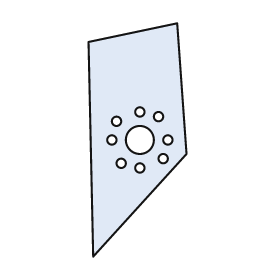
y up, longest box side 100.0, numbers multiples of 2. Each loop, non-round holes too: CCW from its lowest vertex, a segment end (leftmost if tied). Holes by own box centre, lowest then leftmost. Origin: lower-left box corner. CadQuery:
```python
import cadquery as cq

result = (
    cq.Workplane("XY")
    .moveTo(2.0, 0.0)
    .lineTo(42.0, 44.0)
    .lineTo(38.0, 100.0)
    .lineTo(0.0, 92.0)
    .close()
    .moveTo(22.0, 38.0)
    .circle(2.0)
    .moveTo(14.0, 40.0)
    .circle(2.0)
    .moveTo(32.0, 42.0)
    .circle(2.0)
    .moveTo(10.0, 50.0)
    .circle(2.0)
    .moveTo(22.0, 50.0)
    .circle(6.0)
    .moveTo(34.0, 50.0)
    .circle(2.0)
    .moveTo(12.0, 58.0)
    .circle(2.0)
    .moveTo(30.0, 60.0)
    .circle(2.0)
    .moveTo(22.0, 62.0)
    .circle(2.0)
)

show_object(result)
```